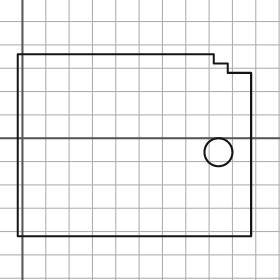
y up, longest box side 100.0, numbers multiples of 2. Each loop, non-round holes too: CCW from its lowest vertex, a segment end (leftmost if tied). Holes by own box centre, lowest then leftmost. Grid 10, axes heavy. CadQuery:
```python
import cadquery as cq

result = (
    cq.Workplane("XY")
    .moveTo(-2.0, -42.0)
    .lineTo(98.0, -42.0)
    .lineTo(98.0, 28.0)
    .lineTo(88.0, 28.0)
    .lineTo(88.0, 32.0)
    .lineTo(82.0, 32.0)
    .lineTo(82.0, 36.0)
    .lineTo(-2.0, 36.0)
    .close()
    .moveTo(84.0, -6.0)
    .circle(6.0)
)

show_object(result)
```